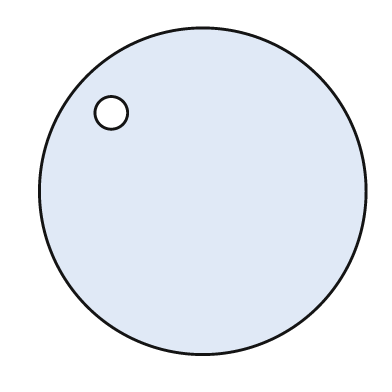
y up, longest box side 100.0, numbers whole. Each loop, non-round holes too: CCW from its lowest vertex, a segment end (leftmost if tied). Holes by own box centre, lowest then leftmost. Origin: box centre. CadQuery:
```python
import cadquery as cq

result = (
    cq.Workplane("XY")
    .moveTo(0.0, 0.0)
    .circle(50.0)
    .moveTo(-28.0, 24.0)
    .circle(5.0)
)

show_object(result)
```